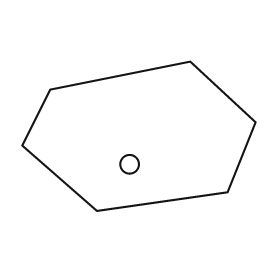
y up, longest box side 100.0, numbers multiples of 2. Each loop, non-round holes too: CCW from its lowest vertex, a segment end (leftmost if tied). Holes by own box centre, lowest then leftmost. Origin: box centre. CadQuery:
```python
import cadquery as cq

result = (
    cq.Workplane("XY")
    .moveTo(-18.0, -32.0)
    .lineTo(38.0, -24.0)
    .lineTo(50.0, 6.0)
    .lineTo(22.0, 32.0)
    .lineTo(-38.0, 20.0)
    .lineTo(-50.0, -4.0)
    .close()
    .moveTo(-4.0, -12.0)
    .circle(4.0)
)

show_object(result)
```